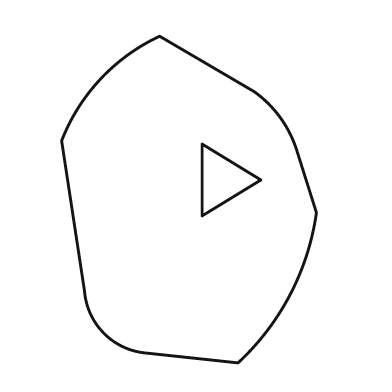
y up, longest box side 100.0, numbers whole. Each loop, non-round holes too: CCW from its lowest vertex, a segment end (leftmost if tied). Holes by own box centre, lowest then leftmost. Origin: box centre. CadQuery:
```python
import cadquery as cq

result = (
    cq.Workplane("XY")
    .moveTo(15.0, -50.0)
    .threePointArc((31.0, -29.0), (39.0, -4.0))
    .lineTo(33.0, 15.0)
    .threePointArc((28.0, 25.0), (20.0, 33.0))
    .lineTo(-9.0, 50.0)
    .threePointArc((-27.0, 37.0), (-39.0, 18.0))
    .lineTo(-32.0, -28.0)
    .threePointArc((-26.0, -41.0), (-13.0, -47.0))
    .close()
    .moveTo(4.0, -5.0)
    .lineTo(22.0, 6.0)
    .lineTo(4.0, 17.0)
    .close()
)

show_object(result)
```